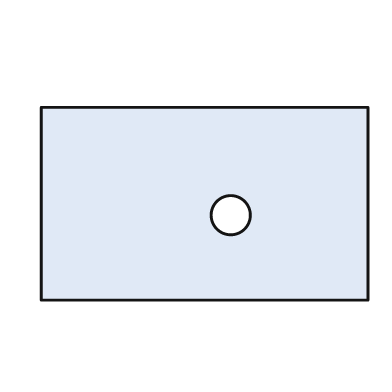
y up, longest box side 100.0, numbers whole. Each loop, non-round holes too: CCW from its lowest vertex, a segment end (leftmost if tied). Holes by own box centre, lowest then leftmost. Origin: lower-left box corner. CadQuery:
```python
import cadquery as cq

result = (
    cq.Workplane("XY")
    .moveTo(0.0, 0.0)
    .lineTo(100.0, 0.0)
    .lineTo(100.0, 59.0)
    .lineTo(0.0, 59.0)
    .close()
    .moveTo(58.0, 26.0)
    .circle(6.0)
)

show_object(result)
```